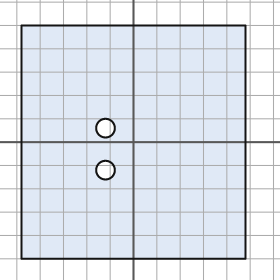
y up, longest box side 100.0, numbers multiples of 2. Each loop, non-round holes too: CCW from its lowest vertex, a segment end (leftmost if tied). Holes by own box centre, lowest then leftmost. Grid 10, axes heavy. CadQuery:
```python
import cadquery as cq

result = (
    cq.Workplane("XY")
    .moveTo(-48.0, -50.0)
    .lineTo(48.0, -50.0)
    .lineTo(48.0, 50.0)
    .lineTo(-48.0, 50.0)
    .close()
    .moveTo(-12.0, -12.0)
    .circle(4.0)
    .moveTo(-12.0, 6.0)
    .circle(4.0)
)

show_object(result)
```